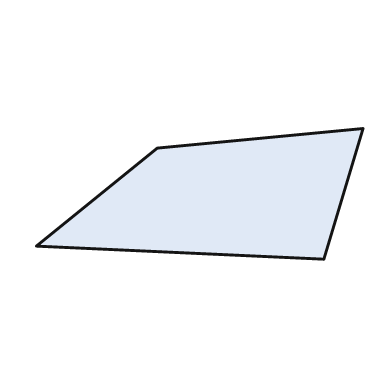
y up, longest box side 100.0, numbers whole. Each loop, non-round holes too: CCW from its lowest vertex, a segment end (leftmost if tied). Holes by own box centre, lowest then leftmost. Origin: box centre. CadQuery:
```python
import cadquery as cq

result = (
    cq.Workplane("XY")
    .moveTo(38.0, -20.0)
    .lineTo(50.0, 20.0)
    .lineTo(-13.0, 14.0)
    .lineTo(-50.0, -16.0)
    .close()
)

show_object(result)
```